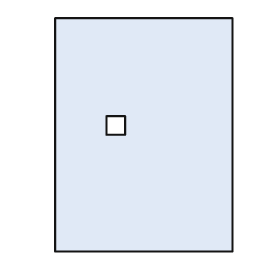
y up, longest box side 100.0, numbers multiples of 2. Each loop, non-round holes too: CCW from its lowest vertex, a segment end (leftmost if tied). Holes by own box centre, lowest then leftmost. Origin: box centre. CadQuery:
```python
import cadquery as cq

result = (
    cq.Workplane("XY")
    .moveTo(-38.0, -50.0)
    .lineTo(38.0, -50.0)
    .lineTo(38.0, 50.0)
    .lineTo(-38.0, 50.0)
    .close()
    .moveTo(-16.0, 0.0)
    .lineTo(-8.0, 0.0)
    .lineTo(-8.0, 8.0)
    .lineTo(-16.0, 8.0)
    .close()
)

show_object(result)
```